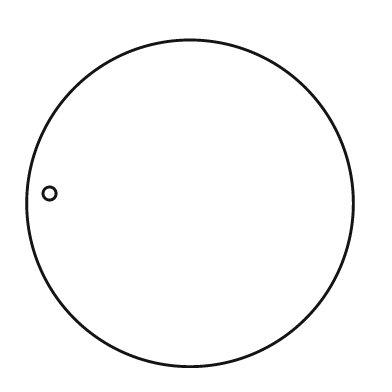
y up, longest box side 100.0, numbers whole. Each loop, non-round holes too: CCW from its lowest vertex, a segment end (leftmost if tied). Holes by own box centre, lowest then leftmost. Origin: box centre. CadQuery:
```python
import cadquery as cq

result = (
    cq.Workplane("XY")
    .moveTo(0.0, 0.0)
    .circle(50.0)
    .moveTo(-43.0, 3.0)
    .circle(2.0)
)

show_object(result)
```